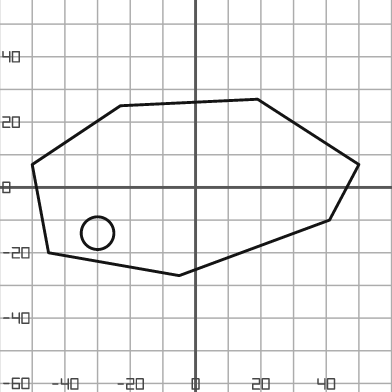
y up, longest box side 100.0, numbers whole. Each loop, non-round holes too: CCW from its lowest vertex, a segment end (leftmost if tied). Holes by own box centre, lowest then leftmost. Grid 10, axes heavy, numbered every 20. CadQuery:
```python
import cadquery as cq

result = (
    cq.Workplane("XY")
    .moveTo(-5.0, -27.0)
    .lineTo(41.0, -10.0)
    .lineTo(50.0, 7.0)
    .lineTo(19.0, 27.0)
    .lineTo(-23.0, 25.0)
    .lineTo(-50.0, 7.0)
    .lineTo(-45.0, -20.0)
    .close()
    .moveTo(-30.0, -14.0)
    .circle(5.0)
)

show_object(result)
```